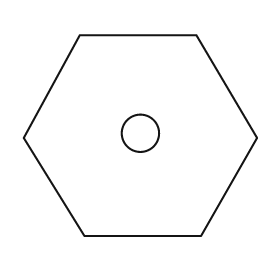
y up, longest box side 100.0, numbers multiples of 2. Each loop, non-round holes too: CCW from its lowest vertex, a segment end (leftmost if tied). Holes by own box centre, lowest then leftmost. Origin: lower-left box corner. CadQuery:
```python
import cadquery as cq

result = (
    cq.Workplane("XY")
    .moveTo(26.0, 0.0)
    .lineTo(76.0, 0.0)
    .lineTo(100.0, 42.0)
    .lineTo(74.0, 86.0)
    .lineTo(24.0, 86.0)
    .lineTo(0.0, 42.0)
    .close()
    .moveTo(50.0, 44.0)
    .circle(8.0)
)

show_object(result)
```